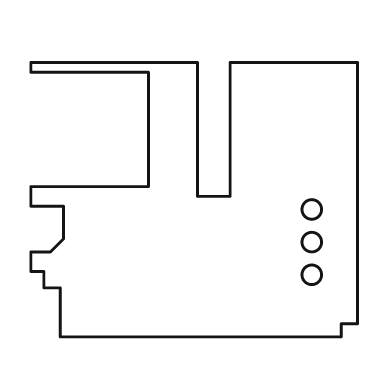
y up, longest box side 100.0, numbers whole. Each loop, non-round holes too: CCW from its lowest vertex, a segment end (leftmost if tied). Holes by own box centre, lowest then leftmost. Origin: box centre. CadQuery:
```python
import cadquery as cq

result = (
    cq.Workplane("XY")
    .moveTo(-41.0, -42.0)
    .lineTo(45.0, -42.0)
    .lineTo(45.0, -38.0)
    .lineTo(50.0, -38.0)
    .lineTo(50.0, 42.0)
    .lineTo(11.0, 42.0)
    .lineTo(11.0, 1.0)
    .lineTo(1.0, 1.0)
    .lineTo(1.0, 42.0)
    .lineTo(-50.0, 42.0)
    .lineTo(-50.0, 39.0)
    .lineTo(-14.0, 39.0)
    .lineTo(-14.0, 4.0)
    .lineTo(-50.0, 4.0)
    .lineTo(-50.0, -2.0)
    .lineTo(-40.0, -2.0)
    .lineTo(-40.0, -12.0)
    .lineTo(-44.0, -16.0)
    .lineTo(-50.0, -16.0)
    .lineTo(-50.0, -22.0)
    .lineTo(-46.0, -22.0)
    .lineTo(-46.0, -27.0)
    .lineTo(-41.0, -27.0)
    .close()
    .moveTo(36.0, -23.0)
    .circle(3.0)
    .moveTo(36.0, -13.0)
    .circle(3.0)
    .moveTo(36.0, -3.0)
    .circle(3.0)
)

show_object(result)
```